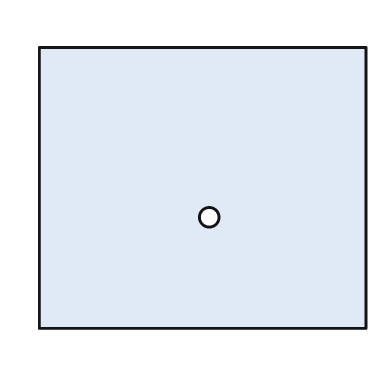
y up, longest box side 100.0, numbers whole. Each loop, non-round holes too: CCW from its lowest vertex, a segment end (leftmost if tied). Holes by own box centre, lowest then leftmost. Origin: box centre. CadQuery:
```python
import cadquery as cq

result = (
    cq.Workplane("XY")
    .moveTo(-50.0, -43.0)
    .lineTo(50.0, -43.0)
    .lineTo(50.0, 43.0)
    .lineTo(-50.0, 43.0)
    .close()
    .moveTo(2.0, -9.0)
    .circle(3.0)
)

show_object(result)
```